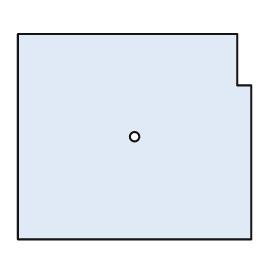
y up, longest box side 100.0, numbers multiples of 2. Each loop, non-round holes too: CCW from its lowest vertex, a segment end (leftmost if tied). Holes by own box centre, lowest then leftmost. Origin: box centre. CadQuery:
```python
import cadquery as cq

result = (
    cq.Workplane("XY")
    .moveTo(-50.0, -44.0)
    .lineTo(50.0, -44.0)
    .lineTo(50.0, 22.0)
    .lineTo(44.0, 22.0)
    .lineTo(44.0, 44.0)
    .lineTo(-50.0, 44.0)
    .close()
    .moveTo(0.0, 0.0)
    .circle(2.0)
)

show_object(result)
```